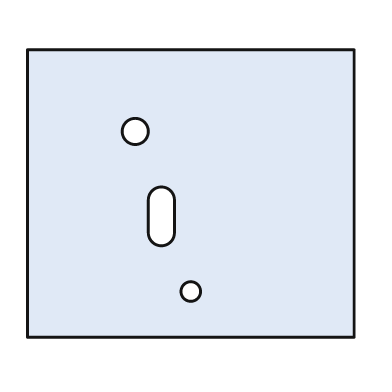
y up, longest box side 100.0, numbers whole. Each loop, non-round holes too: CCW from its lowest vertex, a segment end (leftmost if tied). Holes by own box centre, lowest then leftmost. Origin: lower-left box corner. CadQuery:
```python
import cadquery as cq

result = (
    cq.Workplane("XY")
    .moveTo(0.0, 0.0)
    .lineTo(100.0, 0.0)
    .lineTo(100.0, 88.0)
    .lineTo(0.0, 88.0)
    .close()
    .moveTo(50.0, 14.0)
    .circle(3.0)
    .moveTo(37.0, 32.0)
    .threePointArc((41.0, 28.0), (45.0, 32.0))
    .lineTo(45.0, 42.0)
    .threePointArc((41.0, 46.0), (37.0, 42.0))
    .close()
    .moveTo(33.0, 63.0)
    .circle(4.0)
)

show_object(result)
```